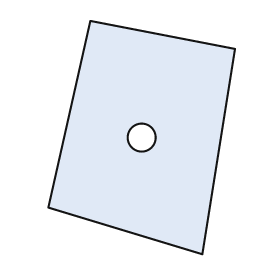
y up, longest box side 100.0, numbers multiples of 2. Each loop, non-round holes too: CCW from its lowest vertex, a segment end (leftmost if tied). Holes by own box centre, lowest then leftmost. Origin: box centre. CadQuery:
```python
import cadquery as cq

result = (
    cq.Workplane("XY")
    .moveTo(26.0, -50.0)
    .lineTo(40.0, 38.0)
    .lineTo(-22.0, 50.0)
    .lineTo(-40.0, -30.0)
    .close()
    .moveTo(0.0, 0.0)
    .circle(6.0)
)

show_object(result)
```